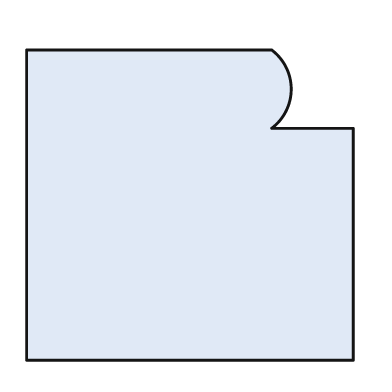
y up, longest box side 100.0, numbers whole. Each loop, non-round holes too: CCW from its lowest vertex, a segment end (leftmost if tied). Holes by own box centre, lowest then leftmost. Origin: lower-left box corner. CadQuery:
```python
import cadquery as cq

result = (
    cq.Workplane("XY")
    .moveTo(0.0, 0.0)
    .lineTo(100.0, 0.0)
    .lineTo(100.0, 71.0)
    .lineTo(75.0, 71.0)
    .threePointArc((81.0, 83.0), (75.0, 95.0))
    .lineTo(0.0, 95.0)
    .close()
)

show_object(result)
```